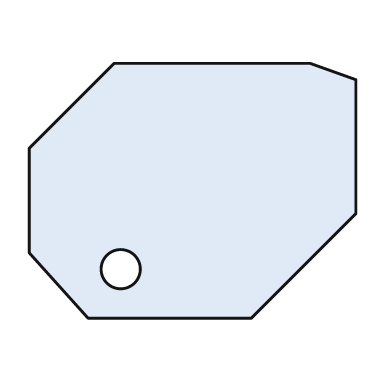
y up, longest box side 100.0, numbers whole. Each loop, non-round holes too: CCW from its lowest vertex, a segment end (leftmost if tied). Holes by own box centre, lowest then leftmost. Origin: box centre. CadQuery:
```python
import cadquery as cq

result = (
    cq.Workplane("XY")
    .moveTo(-32.0, -39.0)
    .lineTo(18.0, -39.0)
    .lineTo(50.0, -7.0)
    .lineTo(50.0, 34.0)
    .lineTo(36.0, 39.0)
    .lineTo(-24.0, 39.0)
    .lineTo(-50.0, 13.0)
    .lineTo(-50.0, -19.0)
    .close()
    .moveTo(-22.0, -24.0)
    .circle(6.0)
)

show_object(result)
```